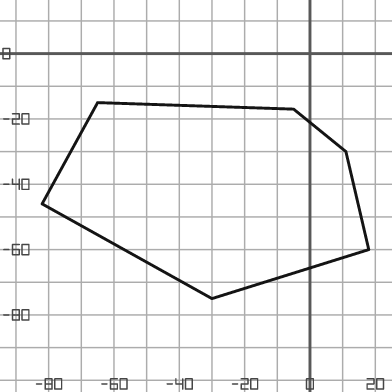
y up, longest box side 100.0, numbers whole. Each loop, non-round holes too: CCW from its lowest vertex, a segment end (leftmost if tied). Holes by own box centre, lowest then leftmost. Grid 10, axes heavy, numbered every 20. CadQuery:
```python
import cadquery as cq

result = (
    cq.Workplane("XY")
    .moveTo(-30.0, -75.0)
    .lineTo(18.0, -60.0)
    .lineTo(11.0, -30.0)
    .lineTo(-5.0, -17.0)
    .lineTo(-65.0, -15.0)
    .lineTo(-82.0, -46.0)
    .close()
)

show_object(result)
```